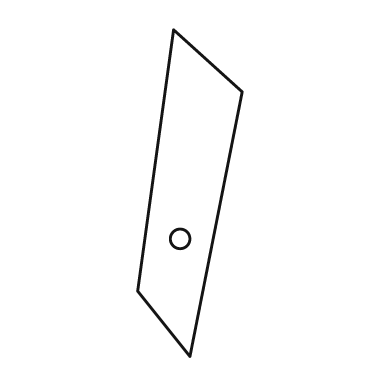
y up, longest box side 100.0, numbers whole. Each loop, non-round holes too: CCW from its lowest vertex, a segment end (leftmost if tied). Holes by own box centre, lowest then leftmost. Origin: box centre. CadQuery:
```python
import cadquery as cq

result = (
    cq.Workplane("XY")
    .moveTo(0.0, -50.0)
    .lineTo(16.0, 31.0)
    .lineTo(-5.0, 50.0)
    .lineTo(-16.0, -30.0)
    .close()
    .moveTo(-3.0, -14.0)
    .circle(3.0)
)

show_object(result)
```